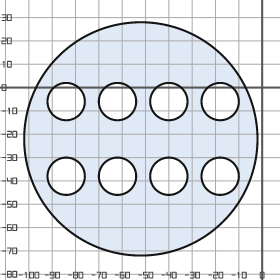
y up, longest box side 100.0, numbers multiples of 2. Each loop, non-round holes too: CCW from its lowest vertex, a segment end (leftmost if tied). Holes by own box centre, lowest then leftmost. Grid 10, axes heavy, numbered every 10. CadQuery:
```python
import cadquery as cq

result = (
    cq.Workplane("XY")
    .moveTo(-52.0, -22.0)
    .circle(50.0)
    .moveTo(-84.0, -38.0)
    .circle(8.0)
    .moveTo(-62.0, -38.0)
    .circle(8.0)
    .moveTo(-40.0, -38.0)
    .circle(8.0)
    .moveTo(-18.0, -38.0)
    .circle(8.0)
    .moveTo(-84.0, -6.0)
    .circle(8.0)
    .moveTo(-62.0, -6.0)
    .circle(8.0)
    .moveTo(-40.0, -6.0)
    .circle(8.0)
    .moveTo(-18.0, -6.0)
    .circle(8.0)
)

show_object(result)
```